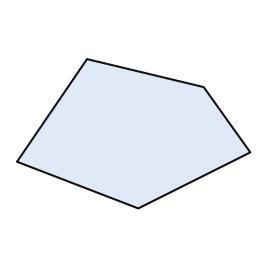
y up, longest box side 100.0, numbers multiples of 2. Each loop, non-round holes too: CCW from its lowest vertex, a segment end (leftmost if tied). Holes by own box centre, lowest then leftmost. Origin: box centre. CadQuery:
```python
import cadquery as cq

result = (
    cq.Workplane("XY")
    .moveTo(2.0, -32.0)
    .lineTo(50.0, -8.0)
    .lineTo(30.0, 20.0)
    .lineTo(-20.0, 32.0)
    .lineTo(-50.0, -12.0)
    .close()
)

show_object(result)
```